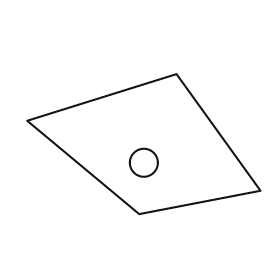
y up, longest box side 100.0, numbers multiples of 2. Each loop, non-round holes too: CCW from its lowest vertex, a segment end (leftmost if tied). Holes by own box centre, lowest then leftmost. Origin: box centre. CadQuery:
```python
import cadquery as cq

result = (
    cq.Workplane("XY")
    .moveTo(-2.0, -30.0)
    .lineTo(50.0, -20.0)
    .lineTo(14.0, 30.0)
    .lineTo(-50.0, 10.0)
    .close()
    .moveTo(0.0, -8.0)
    .circle(6.0)
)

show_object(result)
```